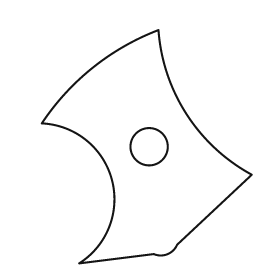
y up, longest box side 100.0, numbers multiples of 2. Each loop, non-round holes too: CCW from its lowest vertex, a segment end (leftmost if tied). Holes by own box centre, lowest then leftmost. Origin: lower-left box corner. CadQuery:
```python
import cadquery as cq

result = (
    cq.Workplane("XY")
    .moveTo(16.0, 0.0)
    .lineTo(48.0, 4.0)
    .threePointArc((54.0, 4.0), (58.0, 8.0))
    .lineTo(90.0, 38.0)
    .threePointArc((62.0, 64.0), (50.0, 100.0))
    .threePointArc((22.0, 84.0), (0.0, 60.0))
    .threePointArc((30.0, 36.0), (16.0, 0.0))
    .close()
    .moveTo(46.0, 50.0)
    .circle(8.0)
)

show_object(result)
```